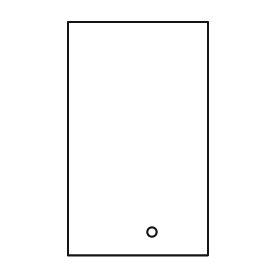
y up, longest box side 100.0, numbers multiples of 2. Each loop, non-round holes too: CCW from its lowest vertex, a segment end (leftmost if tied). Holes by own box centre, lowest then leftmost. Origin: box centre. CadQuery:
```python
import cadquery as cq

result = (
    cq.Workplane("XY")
    .moveTo(-30.0, -50.0)
    .lineTo(30.0, -50.0)
    .lineTo(30.0, 50.0)
    .lineTo(-30.0, 50.0)
    .close()
    .moveTo(6.0, -40.0)
    .circle(2.0)
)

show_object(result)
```